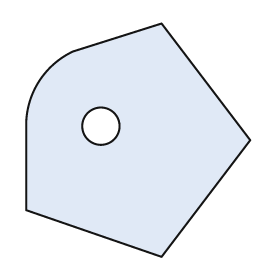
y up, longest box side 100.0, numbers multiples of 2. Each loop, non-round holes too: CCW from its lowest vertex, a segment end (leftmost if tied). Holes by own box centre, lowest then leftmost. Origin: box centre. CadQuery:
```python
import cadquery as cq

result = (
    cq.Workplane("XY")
    .moveTo(10.0, -50.0)
    .lineTo(48.0, 0.0)
    .lineTo(10.0, 50.0)
    .lineTo(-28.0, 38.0)
    .threePointArc((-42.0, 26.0), (-48.0, 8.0))
    .lineTo(-48.0, -30.0)
    .close()
    .moveTo(-16.0, 6.0)
    .circle(8.0)
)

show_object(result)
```